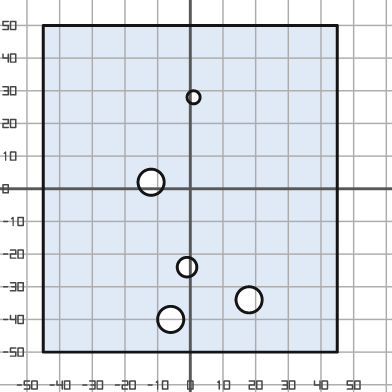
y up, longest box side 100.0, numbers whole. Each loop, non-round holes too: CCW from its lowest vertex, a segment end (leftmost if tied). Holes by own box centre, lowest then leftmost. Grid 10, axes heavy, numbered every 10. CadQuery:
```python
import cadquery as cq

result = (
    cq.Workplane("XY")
    .moveTo(-45.0, -50.0)
    .lineTo(45.0, -50.0)
    .lineTo(45.0, 50.0)
    .lineTo(-45.0, 50.0)
    .close()
    .moveTo(-6.0, -40.0)
    .circle(4.0)
    .moveTo(18.0, -34.0)
    .circle(4.0)
    .moveTo(-1.0, -24.0)
    .circle(3.0)
    .moveTo(-12.0, 2.0)
    .circle(4.0)
    .moveTo(1.0, 28.0)
    .circle(2.0)
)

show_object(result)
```